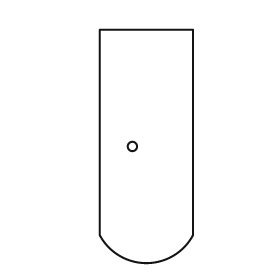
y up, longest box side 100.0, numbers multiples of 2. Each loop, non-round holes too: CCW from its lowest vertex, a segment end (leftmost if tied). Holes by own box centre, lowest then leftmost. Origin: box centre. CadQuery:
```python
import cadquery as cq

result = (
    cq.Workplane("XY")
    .moveTo(-20.0, -38.0)
    .threePointArc((0.0, -50.0), (20.0, -38.0))
    .lineTo(20.0, 50.0)
    .lineTo(-20.0, 50.0)
    .close()
    .moveTo(-6.0, 0.0)
    .circle(2.0)
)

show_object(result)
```